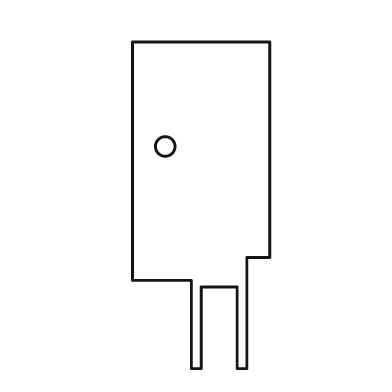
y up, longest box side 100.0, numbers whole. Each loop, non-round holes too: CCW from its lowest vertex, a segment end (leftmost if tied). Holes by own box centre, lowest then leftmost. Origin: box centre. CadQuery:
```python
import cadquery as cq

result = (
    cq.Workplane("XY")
    .moveTo(-3.0, -50.0)
    .lineTo(0.0, -50.0)
    .lineTo(0.0, -25.0)
    .lineTo(11.0, -25.0)
    .lineTo(11.0, -50.0)
    .lineTo(14.0, -50.0)
    .lineTo(14.0, -16.0)
    .lineTo(21.0, -16.0)
    .lineTo(21.0, 50.0)
    .lineTo(-21.0, 50.0)
    .lineTo(-21.0, -23.0)
    .lineTo(-3.0, -23.0)
    .close()
    .moveTo(-11.0, 18.0)
    .circle(3.0)
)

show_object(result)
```